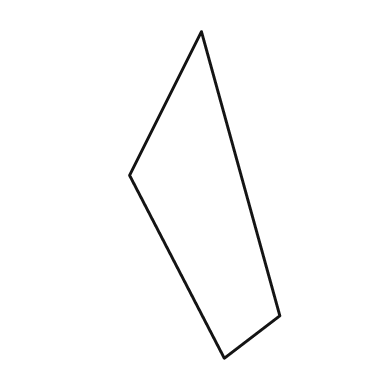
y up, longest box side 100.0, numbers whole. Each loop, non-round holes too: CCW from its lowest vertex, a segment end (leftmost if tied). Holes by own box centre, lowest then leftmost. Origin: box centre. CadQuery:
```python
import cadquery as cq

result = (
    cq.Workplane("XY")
    .moveTo(6.0, -50.0)
    .lineTo(23.0, -37.0)
    .lineTo(-1.0, 50.0)
    .lineTo(-23.0, 6.0)
    .close()
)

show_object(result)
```